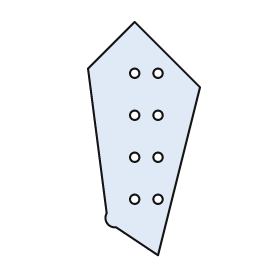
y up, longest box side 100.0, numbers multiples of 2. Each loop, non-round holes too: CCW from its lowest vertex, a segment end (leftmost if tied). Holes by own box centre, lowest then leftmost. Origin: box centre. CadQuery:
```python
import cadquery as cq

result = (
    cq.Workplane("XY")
    .moveTo(6.0, -50.0)
    .lineTo(24.0, 22.0)
    .lineTo(-4.0, 50.0)
    .lineTo(-24.0, 30.0)
    .lineTo(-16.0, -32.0)
    .threePointArc((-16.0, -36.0), (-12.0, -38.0))
    .close()
    .moveTo(-4.0, -26.0)
    .circle(2.0)
    .moveTo(6.0, -26.0)
    .circle(2.0)
    .moveTo(-4.0, -8.0)
    .circle(2.0)
    .moveTo(6.0, -8.0)
    .circle(2.0)
    .moveTo(-4.0, 10.0)
    .circle(2.0)
    .moveTo(6.0, 10.0)
    .circle(2.0)
    .moveTo(-4.0, 28.0)
    .circle(2.0)
    .moveTo(6.0, 28.0)
    .circle(2.0)
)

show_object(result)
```